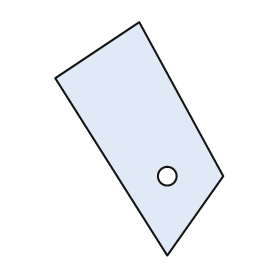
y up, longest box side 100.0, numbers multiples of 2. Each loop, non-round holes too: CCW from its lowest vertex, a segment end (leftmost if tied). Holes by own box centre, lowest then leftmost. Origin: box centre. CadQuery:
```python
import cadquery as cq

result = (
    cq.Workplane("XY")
    .moveTo(12.0, -50.0)
    .lineTo(36.0, -16.0)
    .lineTo(0.0, 50.0)
    .lineTo(-36.0, 26.0)
    .close()
    .moveTo(12.0, -16.0)
    .circle(4.0)
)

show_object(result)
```